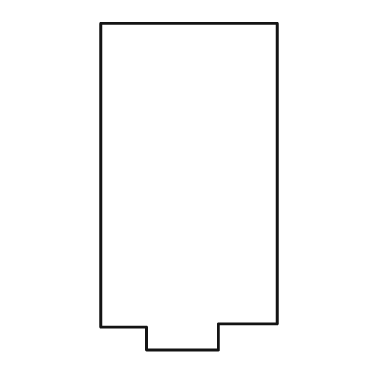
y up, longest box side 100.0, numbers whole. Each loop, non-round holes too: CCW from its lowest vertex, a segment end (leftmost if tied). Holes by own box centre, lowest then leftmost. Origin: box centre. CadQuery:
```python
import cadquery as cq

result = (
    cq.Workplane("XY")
    .moveTo(-13.0, -50.0)
    .lineTo(9.0, -50.0)
    .lineTo(9.0, -42.0)
    .lineTo(27.0, -42.0)
    .lineTo(27.0, 50.0)
    .lineTo(-27.0, 50.0)
    .lineTo(-27.0, -43.0)
    .lineTo(-13.0, -43.0)
    .close()
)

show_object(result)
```